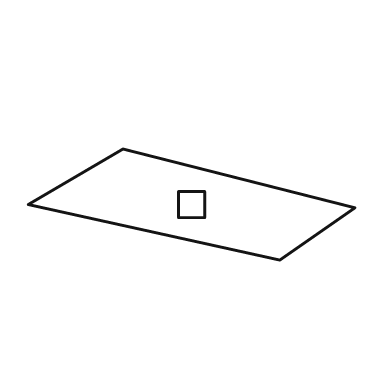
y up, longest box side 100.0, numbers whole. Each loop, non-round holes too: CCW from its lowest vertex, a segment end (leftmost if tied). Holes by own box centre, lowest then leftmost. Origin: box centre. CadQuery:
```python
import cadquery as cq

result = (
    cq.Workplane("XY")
    .moveTo(27.0, -17.0)
    .lineTo(50.0, -1.0)
    .lineTo(-21.0, 17.0)
    .lineTo(-50.0, 0.0)
    .close()
    .moveTo(-4.0, -4.0)
    .lineTo(4.0, -4.0)
    .lineTo(4.0, 4.0)
    .lineTo(-4.0, 4.0)
    .close()
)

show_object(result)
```